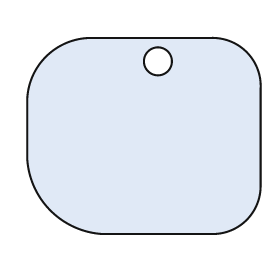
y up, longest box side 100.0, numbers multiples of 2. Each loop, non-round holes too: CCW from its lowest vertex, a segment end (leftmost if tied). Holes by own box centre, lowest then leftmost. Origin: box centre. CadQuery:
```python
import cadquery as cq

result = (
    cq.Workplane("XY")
    .moveTo(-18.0, -42.0)
    .lineTo(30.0, -42.0)
    .threePointArc((44.0, -36.0), (50.0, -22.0))
    .lineTo(50.0, 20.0)
    .threePointArc((44.0, 36.0), (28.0, 42.0))
    .lineTo(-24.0, 42.0)
    .threePointArc((-42.0, 34.0), (-50.0, 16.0))
    .lineTo(-50.0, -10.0)
    .threePointArc((-40.0, -32.0), (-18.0, -42.0))
    .close()
    .moveTo(6.0, 32.0)
    .circle(6.0)
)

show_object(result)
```